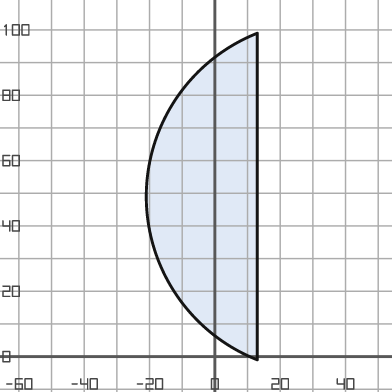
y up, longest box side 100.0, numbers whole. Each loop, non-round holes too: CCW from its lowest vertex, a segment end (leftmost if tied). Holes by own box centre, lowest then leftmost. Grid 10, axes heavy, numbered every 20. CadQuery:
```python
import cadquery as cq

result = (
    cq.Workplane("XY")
    .moveTo(13.0, -1.0)
    .lineTo(13.0, 99.0)
    .threePointArc((-21.0, 49.0), (13.0, -1.0))
    .close()
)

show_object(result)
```